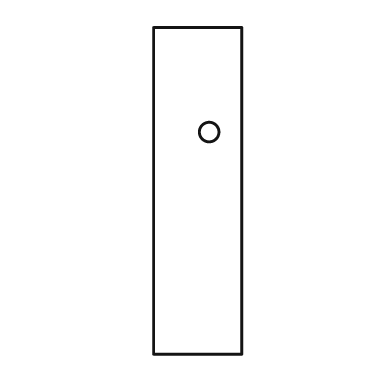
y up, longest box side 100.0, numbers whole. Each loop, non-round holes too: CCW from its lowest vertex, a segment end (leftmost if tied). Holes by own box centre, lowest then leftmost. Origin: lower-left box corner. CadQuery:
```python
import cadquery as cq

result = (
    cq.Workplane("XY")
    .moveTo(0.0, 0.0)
    .lineTo(27.0, 0.0)
    .lineTo(27.0, 100.0)
    .lineTo(0.0, 100.0)
    .close()
    .moveTo(17.0, 68.0)
    .circle(3.0)
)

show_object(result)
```